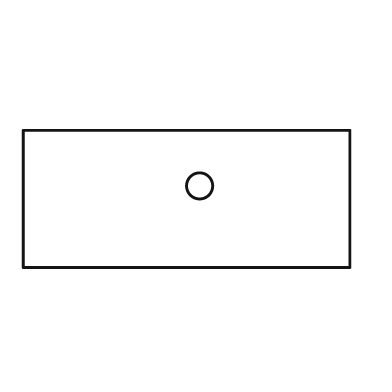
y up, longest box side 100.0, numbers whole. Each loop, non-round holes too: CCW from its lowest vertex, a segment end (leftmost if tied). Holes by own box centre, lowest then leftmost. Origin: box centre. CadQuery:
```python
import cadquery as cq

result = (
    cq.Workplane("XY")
    .moveTo(-50.0, -21.0)
    .lineTo(50.0, -21.0)
    .lineTo(50.0, 21.0)
    .lineTo(-50.0, 21.0)
    .close()
    .moveTo(4.0, 4.0)
    .circle(4.0)
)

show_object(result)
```